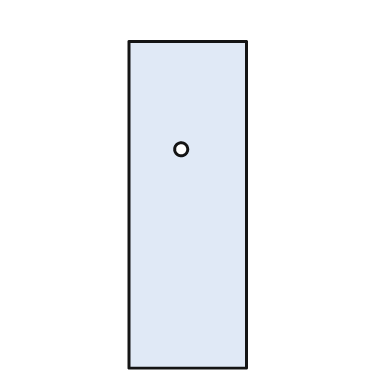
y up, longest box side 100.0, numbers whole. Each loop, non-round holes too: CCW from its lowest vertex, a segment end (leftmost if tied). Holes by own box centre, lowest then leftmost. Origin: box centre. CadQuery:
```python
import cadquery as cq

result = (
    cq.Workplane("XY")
    .moveTo(-18.0, -50.0)
    .lineTo(18.0, -50.0)
    .lineTo(18.0, 50.0)
    .lineTo(-18.0, 50.0)
    .close()
    .moveTo(-2.0, 17.0)
    .circle(2.0)
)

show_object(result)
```